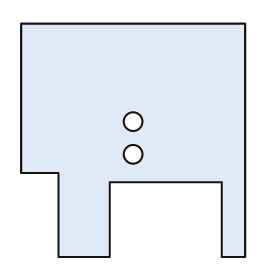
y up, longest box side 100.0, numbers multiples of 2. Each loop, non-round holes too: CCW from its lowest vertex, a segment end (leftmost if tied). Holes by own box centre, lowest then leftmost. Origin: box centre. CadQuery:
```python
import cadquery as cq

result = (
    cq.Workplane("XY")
    .moveTo(-32.0, -50.0)
    .lineTo(-10.0, -50.0)
    .lineTo(-10.0, -18.0)
    .lineTo(38.0, -18.0)
    .lineTo(38.0, -50.0)
    .lineTo(48.0, -50.0)
    .lineTo(48.0, 50.0)
    .lineTo(-48.0, 50.0)
    .lineTo(-48.0, -14.0)
    .lineTo(-32.0, -14.0)
    .close()
    .moveTo(0.0, -6.0)
    .circle(4.0)
    .moveTo(0.0, 8.0)
    .circle(4.0)
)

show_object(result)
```